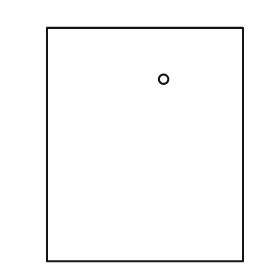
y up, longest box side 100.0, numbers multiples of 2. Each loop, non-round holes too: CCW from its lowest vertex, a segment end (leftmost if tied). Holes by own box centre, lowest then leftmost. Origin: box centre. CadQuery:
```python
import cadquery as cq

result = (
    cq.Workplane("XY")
    .moveTo(-42.0, -50.0)
    .lineTo(42.0, -50.0)
    .lineTo(42.0, 50.0)
    .lineTo(-42.0, 50.0)
    .close()
    .moveTo(8.0, 28.0)
    .circle(2.0)
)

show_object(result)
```